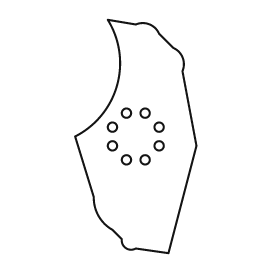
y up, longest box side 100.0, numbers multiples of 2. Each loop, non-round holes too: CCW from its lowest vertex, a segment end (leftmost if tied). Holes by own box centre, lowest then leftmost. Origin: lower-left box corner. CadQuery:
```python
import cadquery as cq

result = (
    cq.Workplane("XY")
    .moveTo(40.0, 0.0)
    .lineTo(52.0, 46.0)
    .lineTo(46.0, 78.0)
    .threePointArc((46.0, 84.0), (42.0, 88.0))
    .lineTo(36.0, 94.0)
    .threePointArc((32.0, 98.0), (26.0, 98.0))
    .lineTo(14.0, 100.0)
    .threePointArc((18.0, 72.0), (0.0, 50.0))
    .lineTo(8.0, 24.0)
    .threePointArc((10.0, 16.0), (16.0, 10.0))
    .lineTo(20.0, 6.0)
    .threePointArc((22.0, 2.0), (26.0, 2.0))
    .close()
    .moveTo(22.0, 40.0)
    .circle(2.0)
    .moveTo(30.0, 40.0)
    .circle(2.0)
    .moveTo(16.0, 46.0)
    .circle(2.0)
    .moveTo(36.0, 46.0)
    .circle(2.0)
    .moveTo(16.0, 54.0)
    .circle(2.0)
    .moveTo(36.0, 54.0)
    .circle(2.0)
    .moveTo(22.0, 60.0)
    .circle(2.0)
    .moveTo(30.0, 60.0)
    .circle(2.0)
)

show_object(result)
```